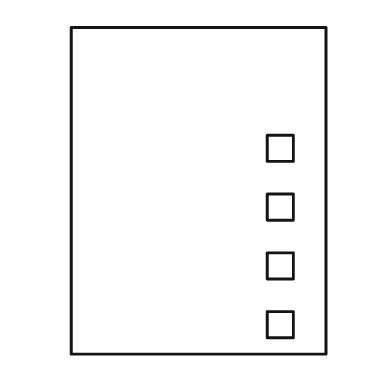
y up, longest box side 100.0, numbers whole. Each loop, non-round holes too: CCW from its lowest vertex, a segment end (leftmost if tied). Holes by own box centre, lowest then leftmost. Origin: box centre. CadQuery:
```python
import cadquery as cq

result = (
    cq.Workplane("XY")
    .moveTo(-39.0, -50.0)
    .lineTo(39.0, -50.0)
    .lineTo(39.0, 50.0)
    .lineTo(-39.0, 50.0)
    .close()
    .moveTo(21.0, -45.0)
    .lineTo(29.0, -45.0)
    .lineTo(29.0, -37.0)
    .lineTo(21.0, -37.0)
    .close()
    .moveTo(21.0, -27.0)
    .lineTo(29.0, -27.0)
    .lineTo(29.0, -19.0)
    .lineTo(21.0, -19.0)
    .close()
    .moveTo(21.0, -9.0)
    .lineTo(29.0, -9.0)
    .lineTo(29.0, -1.0)
    .lineTo(21.0, -1.0)
    .close()
    .moveTo(21.0, 9.0)
    .lineTo(29.0, 9.0)
    .lineTo(29.0, 17.0)
    .lineTo(21.0, 17.0)
    .close()
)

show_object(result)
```